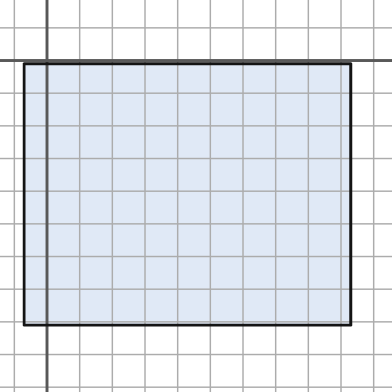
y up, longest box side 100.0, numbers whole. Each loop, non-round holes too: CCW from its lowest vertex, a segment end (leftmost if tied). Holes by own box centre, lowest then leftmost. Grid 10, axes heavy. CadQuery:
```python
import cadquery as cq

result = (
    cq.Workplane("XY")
    .moveTo(-7.0, -81.0)
    .lineTo(93.0, -81.0)
    .lineTo(93.0, -1.0)
    .lineTo(-7.0, -1.0)
    .close()
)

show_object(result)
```